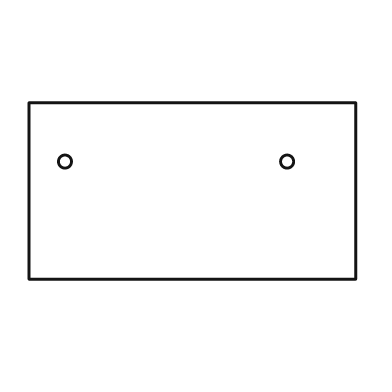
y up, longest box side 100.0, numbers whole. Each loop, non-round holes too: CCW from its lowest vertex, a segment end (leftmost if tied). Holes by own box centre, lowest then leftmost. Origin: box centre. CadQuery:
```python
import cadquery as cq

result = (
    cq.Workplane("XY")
    .moveTo(-50.0, -27.0)
    .lineTo(50.0, -27.0)
    .lineTo(50.0, 27.0)
    .lineTo(-50.0, 27.0)
    .close()
    .moveTo(-39.0, 9.0)
    .circle(2.0)
    .moveTo(29.0, 9.0)
    .circle(2.0)
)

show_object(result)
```